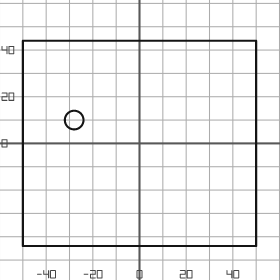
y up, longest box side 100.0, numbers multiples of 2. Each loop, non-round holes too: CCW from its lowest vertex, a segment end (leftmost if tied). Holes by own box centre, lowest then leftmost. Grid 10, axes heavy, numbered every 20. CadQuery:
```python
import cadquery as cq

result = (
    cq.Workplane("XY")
    .moveTo(-50.0, -44.0)
    .lineTo(50.0, -44.0)
    .lineTo(50.0, 44.0)
    .lineTo(-50.0, 44.0)
    .close()
    .moveTo(-28.0, 10.0)
    .circle(4.0)
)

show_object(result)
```